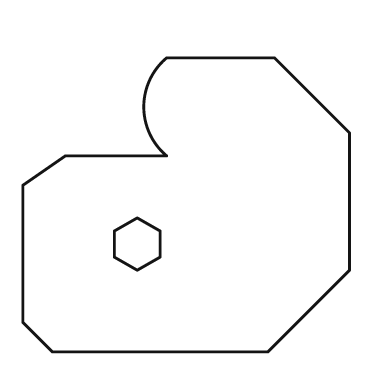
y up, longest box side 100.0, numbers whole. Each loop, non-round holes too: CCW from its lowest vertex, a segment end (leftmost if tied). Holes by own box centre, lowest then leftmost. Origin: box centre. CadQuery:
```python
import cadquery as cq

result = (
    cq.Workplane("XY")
    .moveTo(-41.0, -45.0)
    .lineTo(25.0, -45.0)
    .lineTo(50.0, -20.0)
    .lineTo(50.0, 22.0)
    .lineTo(27.0, 45.0)
    .lineTo(-6.0, 45.0)
    .threePointArc((-13.0, 30.0), (-6.0, 15.0))
    .lineTo(-37.0, 15.0)
    .lineTo(-50.0, 6.0)
    .lineTo(-50.0, -36.0)
    .close()
    .moveTo(-15.0, -20.0)
    .lineTo(-8.0, -16.0)
    .lineTo(-8.0, -8.0)
    .lineTo(-15.0, -4.0)
    .lineTo(-22.0, -8.0)
    .lineTo(-22.0, -16.0)
    .close()
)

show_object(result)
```